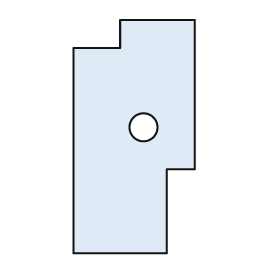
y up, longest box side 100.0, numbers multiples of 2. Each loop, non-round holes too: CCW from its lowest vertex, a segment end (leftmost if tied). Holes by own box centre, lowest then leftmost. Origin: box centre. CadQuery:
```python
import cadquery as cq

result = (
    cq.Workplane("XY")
    .moveTo(-26.0, -50.0)
    .lineTo(14.0, -50.0)
    .lineTo(14.0, -14.0)
    .lineTo(26.0, -14.0)
    .lineTo(26.0, 50.0)
    .lineTo(-6.0, 50.0)
    .lineTo(-6.0, 38.0)
    .lineTo(-26.0, 38.0)
    .close()
    .moveTo(4.0, 4.0)
    .circle(6.0)
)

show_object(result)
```